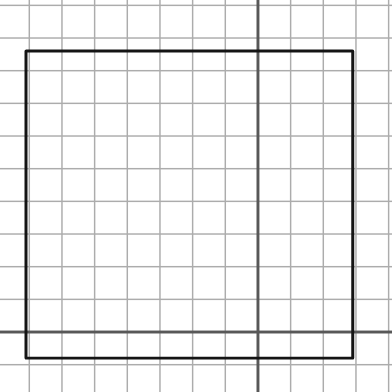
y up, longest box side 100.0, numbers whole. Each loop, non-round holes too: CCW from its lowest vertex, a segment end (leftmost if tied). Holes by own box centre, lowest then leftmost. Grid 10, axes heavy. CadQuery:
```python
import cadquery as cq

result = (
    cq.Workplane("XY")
    .moveTo(-71.0, -8.0)
    .lineTo(29.0, -8.0)
    .lineTo(29.0, 86.0)
    .lineTo(-71.0, 86.0)
    .close()
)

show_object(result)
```